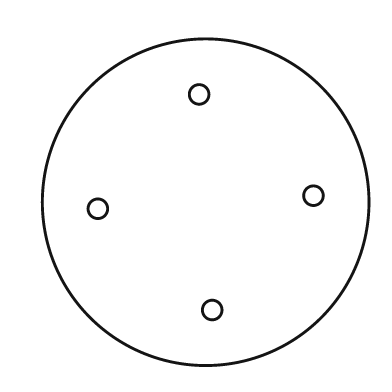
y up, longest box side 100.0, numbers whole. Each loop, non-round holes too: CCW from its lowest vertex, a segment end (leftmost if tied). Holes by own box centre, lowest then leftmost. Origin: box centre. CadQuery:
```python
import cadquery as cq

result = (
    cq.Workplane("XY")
    .moveTo(0.0, 0.0)
    .circle(50.0)
    .moveTo(2.0, -33.0)
    .circle(3.0)
    .moveTo(-33.0, -2.0)
    .circle(3.0)
    .moveTo(33.0, 2.0)
    .circle(3.0)
    .moveTo(-2.0, 33.0)
    .circle(3.0)
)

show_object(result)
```